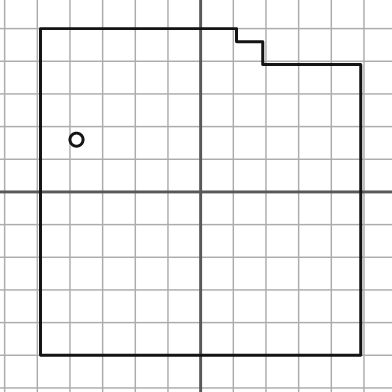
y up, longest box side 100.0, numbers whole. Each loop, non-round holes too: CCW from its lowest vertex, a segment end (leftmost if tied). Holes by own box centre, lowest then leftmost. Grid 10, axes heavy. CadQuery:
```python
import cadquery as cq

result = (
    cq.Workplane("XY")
    .moveTo(-49.0, -50.0)
    .lineTo(49.0, -50.0)
    .lineTo(49.0, 39.0)
    .lineTo(19.0, 39.0)
    .lineTo(19.0, 46.0)
    .lineTo(11.0, 46.0)
    .lineTo(11.0, 50.0)
    .lineTo(-49.0, 50.0)
    .close()
    .moveTo(-38.0, 16.0)
    .circle(2.0)
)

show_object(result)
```